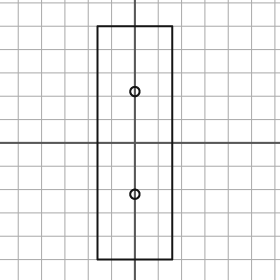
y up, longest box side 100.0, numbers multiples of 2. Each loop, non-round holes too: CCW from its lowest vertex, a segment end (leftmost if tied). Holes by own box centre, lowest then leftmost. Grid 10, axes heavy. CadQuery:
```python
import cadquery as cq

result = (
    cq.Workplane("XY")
    .moveTo(-16.0, -50.0)
    .lineTo(16.0, -50.0)
    .lineTo(16.0, 50.0)
    .lineTo(-16.0, 50.0)
    .close()
    .moveTo(0.0, -22.0)
    .circle(2.0)
    .moveTo(0.0, 22.0)
    .circle(2.0)
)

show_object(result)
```